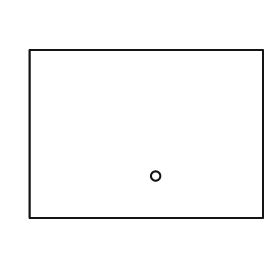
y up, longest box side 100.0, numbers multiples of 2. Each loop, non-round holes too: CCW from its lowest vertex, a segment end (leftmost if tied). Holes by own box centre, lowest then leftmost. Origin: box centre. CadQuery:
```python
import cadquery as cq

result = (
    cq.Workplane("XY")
    .moveTo(-50.0, -36.0)
    .lineTo(50.0, -36.0)
    .lineTo(50.0, 36.0)
    .lineTo(-50.0, 36.0)
    .close()
    .moveTo(4.0, -18.0)
    .circle(2.0)
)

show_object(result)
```